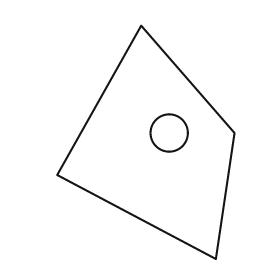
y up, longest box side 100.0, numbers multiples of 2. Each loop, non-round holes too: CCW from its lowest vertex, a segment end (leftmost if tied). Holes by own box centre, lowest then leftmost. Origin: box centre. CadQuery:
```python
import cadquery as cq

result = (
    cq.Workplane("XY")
    .moveTo(30.0, -50.0)
    .lineTo(38.0, 4.0)
    .lineTo(-2.0, 50.0)
    .lineTo(-38.0, -14.0)
    .close()
    .moveTo(10.0, 4.0)
    .circle(8.0)
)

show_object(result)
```